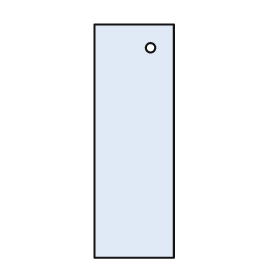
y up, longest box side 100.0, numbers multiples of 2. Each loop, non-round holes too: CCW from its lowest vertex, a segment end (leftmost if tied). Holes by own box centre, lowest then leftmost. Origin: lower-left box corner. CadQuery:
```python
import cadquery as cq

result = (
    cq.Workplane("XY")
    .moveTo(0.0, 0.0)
    .lineTo(34.0, 0.0)
    .lineTo(34.0, 100.0)
    .lineTo(0.0, 100.0)
    .close()
    .moveTo(24.0, 90.0)
    .circle(2.0)
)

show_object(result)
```